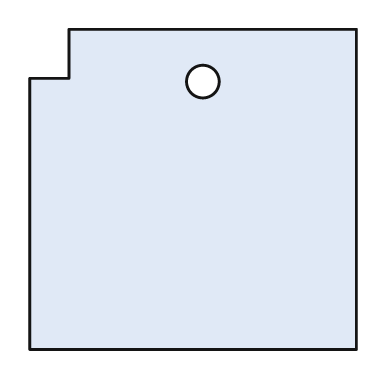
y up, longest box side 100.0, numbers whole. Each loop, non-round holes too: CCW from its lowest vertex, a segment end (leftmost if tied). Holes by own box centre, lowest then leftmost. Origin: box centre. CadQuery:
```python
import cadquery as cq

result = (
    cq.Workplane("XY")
    .moveTo(-50.0, -49.0)
    .lineTo(50.0, -49.0)
    .lineTo(50.0, 49.0)
    .lineTo(-38.0, 49.0)
    .lineTo(-38.0, 34.0)
    .lineTo(-50.0, 34.0)
    .close()
    .moveTo(3.0, 33.0)
    .circle(5.0)
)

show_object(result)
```